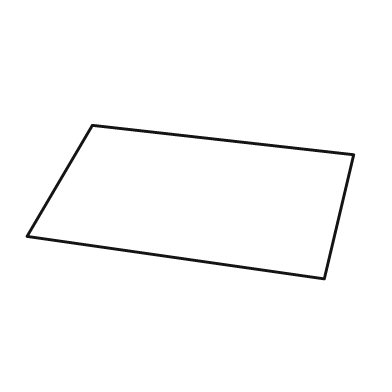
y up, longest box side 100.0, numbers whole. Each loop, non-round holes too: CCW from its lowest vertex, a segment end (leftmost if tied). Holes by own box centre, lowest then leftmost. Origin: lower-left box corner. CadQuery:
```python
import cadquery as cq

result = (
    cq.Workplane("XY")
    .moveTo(91.0, 0.0)
    .lineTo(100.0, 38.0)
    .lineTo(20.0, 47.0)
    .lineTo(0.0, 13.0)
    .close()
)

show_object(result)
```